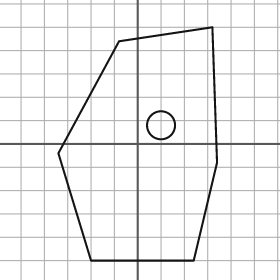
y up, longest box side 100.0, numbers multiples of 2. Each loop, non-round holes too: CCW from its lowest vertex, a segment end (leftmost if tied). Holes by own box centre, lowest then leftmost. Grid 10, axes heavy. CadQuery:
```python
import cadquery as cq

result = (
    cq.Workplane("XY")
    .moveTo(-20.0, -50.0)
    .lineTo(24.0, -50.0)
    .lineTo(34.0, -8.0)
    .lineTo(32.0, 50.0)
    .lineTo(-8.0, 44.0)
    .lineTo(-34.0, -4.0)
    .close()
    .moveTo(10.0, 8.0)
    .circle(6.0)
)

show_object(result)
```